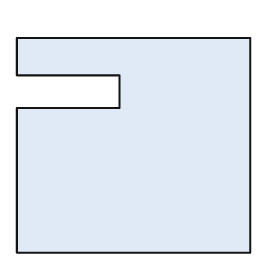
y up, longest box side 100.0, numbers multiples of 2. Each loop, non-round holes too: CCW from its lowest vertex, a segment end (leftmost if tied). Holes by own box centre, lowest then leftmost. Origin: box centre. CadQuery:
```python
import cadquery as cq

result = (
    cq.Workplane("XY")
    .moveTo(-50.0, -46.0)
    .lineTo(50.0, -46.0)
    .lineTo(50.0, 46.0)
    .lineTo(-50.0, 46.0)
    .lineTo(-50.0, 30.0)
    .lineTo(-6.0, 30.0)
    .lineTo(-6.0, 16.0)
    .lineTo(-50.0, 16.0)
    .close()
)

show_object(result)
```